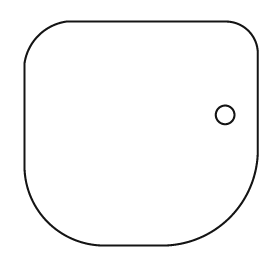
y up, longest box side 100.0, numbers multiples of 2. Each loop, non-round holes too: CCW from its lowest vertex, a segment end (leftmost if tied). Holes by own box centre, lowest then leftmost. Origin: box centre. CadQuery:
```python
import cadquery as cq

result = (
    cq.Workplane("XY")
    .moveTo(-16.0, -48.0)
    .lineTo(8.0, -48.0)
    .threePointArc((38.0, -36.0), (50.0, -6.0))
    .lineTo(50.0, 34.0)
    .threePointArc((46.0, 44.0), (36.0, 48.0))
    .lineTo(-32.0, 48.0)
    .threePointArc((-44.0, 42.0), (-50.0, 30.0))
    .lineTo(-50.0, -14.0)
    .threePointArc((-40.0, -38.0), (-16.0, -48.0))
    .close()
    .moveTo(36.0, 8.0)
    .circle(4.0)
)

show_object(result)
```